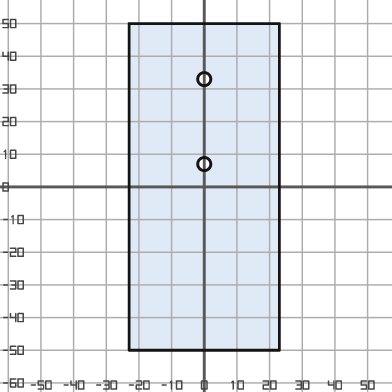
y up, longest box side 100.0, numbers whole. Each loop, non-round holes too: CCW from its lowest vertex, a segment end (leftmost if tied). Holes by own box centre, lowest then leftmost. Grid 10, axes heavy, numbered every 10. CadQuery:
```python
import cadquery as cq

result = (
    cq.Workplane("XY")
    .moveTo(-23.0, -50.0)
    .lineTo(23.0, -50.0)
    .lineTo(23.0, 50.0)
    .lineTo(-23.0, 50.0)
    .close()
    .moveTo(0.0, 7.0)
    .circle(2.0)
    .moveTo(0.0, 33.0)
    .circle(2.0)
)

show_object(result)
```